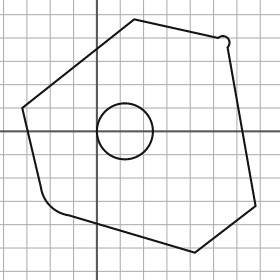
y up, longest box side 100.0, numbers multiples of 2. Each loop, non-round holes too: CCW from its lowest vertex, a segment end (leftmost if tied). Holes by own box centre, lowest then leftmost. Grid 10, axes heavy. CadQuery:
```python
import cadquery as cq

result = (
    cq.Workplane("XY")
    .moveTo(42.0, -52.0)
    .lineTo(68.0, -32.0)
    .lineTo(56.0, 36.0)
    .threePointArc((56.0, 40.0), (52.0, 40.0))
    .lineTo(16.0, 48.0)
    .lineTo(-32.0, 10.0)
    .lineTo(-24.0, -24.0)
    .threePointArc((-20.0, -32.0), (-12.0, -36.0))
    .close()
    .moveTo(12.0, 0.0)
    .circle(12.0)
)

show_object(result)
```